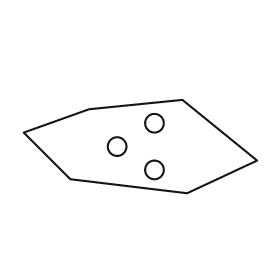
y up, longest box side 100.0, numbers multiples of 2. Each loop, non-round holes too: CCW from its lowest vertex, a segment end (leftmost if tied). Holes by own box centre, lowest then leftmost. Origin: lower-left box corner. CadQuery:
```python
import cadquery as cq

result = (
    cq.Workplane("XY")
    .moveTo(70.0, 0.0)
    .lineTo(100.0, 14.0)
    .lineTo(68.0, 40.0)
    .lineTo(28.0, 36.0)
    .lineTo(0.0, 26.0)
    .lineTo(20.0, 6.0)
    .close()
    .moveTo(56.0, 10.0)
    .circle(4.0)
    .moveTo(40.0, 20.0)
    .circle(4.0)
    .moveTo(56.0, 30.0)
    .circle(4.0)
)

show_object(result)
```